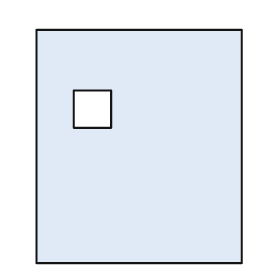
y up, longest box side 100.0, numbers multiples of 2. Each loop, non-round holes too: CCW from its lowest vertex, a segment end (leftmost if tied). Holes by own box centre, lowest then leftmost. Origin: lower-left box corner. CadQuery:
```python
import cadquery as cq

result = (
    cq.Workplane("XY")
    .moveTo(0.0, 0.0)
    .lineTo(88.0, 0.0)
    .lineTo(88.0, 100.0)
    .lineTo(0.0, 100.0)
    .close()
    .moveTo(16.0, 58.0)
    .lineTo(32.0, 58.0)
    .lineTo(32.0, 74.0)
    .lineTo(16.0, 74.0)
    .close()
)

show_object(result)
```